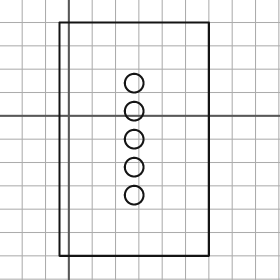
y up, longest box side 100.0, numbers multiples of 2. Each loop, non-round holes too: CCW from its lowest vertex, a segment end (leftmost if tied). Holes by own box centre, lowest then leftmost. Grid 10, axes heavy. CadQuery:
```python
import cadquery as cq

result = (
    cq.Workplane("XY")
    .moveTo(-4.0, -60.0)
    .lineTo(60.0, -60.0)
    .lineTo(60.0, 40.0)
    .lineTo(-4.0, 40.0)
    .close()
    .moveTo(28.0, -34.0)
    .circle(4.0)
    .moveTo(28.0, -22.0)
    .circle(4.0)
    .moveTo(28.0, -10.0)
    .circle(4.0)
    .moveTo(28.0, 2.0)
    .circle(4.0)
    .moveTo(28.0, 14.0)
    .circle(4.0)
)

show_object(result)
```